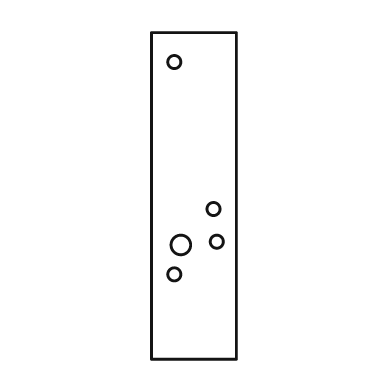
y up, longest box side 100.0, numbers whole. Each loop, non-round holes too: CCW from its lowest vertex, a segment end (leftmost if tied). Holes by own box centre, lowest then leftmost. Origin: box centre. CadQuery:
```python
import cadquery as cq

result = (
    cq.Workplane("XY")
    .moveTo(-13.0, -50.0)
    .lineTo(13.0, -50.0)
    .lineTo(13.0, 50.0)
    .lineTo(-13.0, 50.0)
    .close()
    .moveTo(-6.0, -24.0)
    .circle(2.0)
    .moveTo(-4.0, -15.0)
    .circle(3.0)
    .moveTo(7.0, -14.0)
    .circle(2.0)
    .moveTo(6.0, -4.0)
    .circle(2.0)
    .moveTo(-6.0, 41.0)
    .circle(2.0)
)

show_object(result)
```